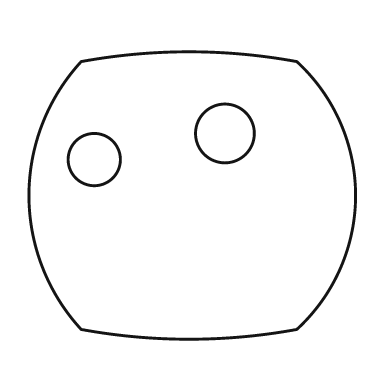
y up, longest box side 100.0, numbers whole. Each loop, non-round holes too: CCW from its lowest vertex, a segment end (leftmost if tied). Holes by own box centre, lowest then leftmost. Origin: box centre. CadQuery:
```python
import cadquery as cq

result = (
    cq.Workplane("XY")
    .moveTo(-34.0, -41.0)
    .threePointArc((-1.0, -44.0), (32.0, -41.0))
    .threePointArc((50.0, 0.0), (32.0, 41.0))
    .threePointArc((-1.0, 44.0), (-34.0, 41.0))
    .threePointArc((-50.0, 0.0), (-34.0, -41.0))
    .close()
    .moveTo(-30.0, 11.0)
    .circle(8.0)
    .moveTo(10.0, 19.0)
    .circle(9.0)
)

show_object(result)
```